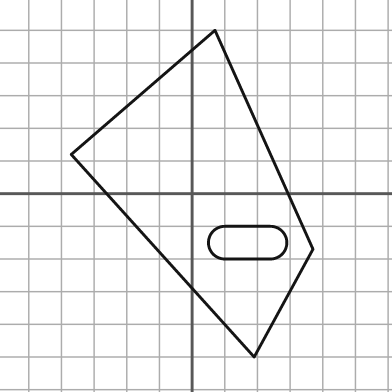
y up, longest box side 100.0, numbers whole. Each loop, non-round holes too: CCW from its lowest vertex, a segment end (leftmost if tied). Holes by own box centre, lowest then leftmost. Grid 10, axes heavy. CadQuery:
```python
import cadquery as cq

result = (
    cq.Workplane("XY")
    .moveTo(19.0, -50.0)
    .lineTo(37.0, -17.0)
    .lineTo(7.0, 50.0)
    .lineTo(-37.0, 12.0)
    .close()
    .moveTo(10.0, -20.0)
    .lineTo(24.0, -20.0)
    .threePointArc((29.0, -15.0), (24.0, -10.0))
    .lineTo(10.0, -10.0)
    .threePointArc((5.0, -15.0), (10.0, -20.0))
    .close()
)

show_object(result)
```